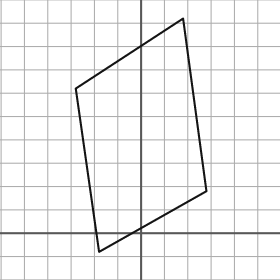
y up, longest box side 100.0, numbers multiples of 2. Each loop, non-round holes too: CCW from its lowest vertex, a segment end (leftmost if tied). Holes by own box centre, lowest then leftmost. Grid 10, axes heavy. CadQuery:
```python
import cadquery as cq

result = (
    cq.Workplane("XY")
    .moveTo(-18.0, -8.0)
    .lineTo(28.0, 18.0)
    .lineTo(18.0, 92.0)
    .lineTo(-28.0, 62.0)
    .close()
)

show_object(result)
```